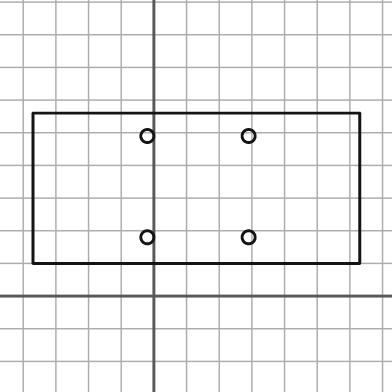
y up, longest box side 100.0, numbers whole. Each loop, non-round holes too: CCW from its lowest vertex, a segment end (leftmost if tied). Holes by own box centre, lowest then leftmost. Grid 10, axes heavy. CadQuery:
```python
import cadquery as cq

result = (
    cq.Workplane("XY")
    .moveTo(-37.0, 10.0)
    .lineTo(63.0, 10.0)
    .lineTo(63.0, 56.0)
    .lineTo(-37.0, 56.0)
    .close()
    .moveTo(-2.0, 18.0)
    .circle(2.0)
    .moveTo(29.0, 18.0)
    .circle(2.0)
    .moveTo(-2.0, 49.0)
    .circle(2.0)
    .moveTo(29.0, 49.0)
    .circle(2.0)
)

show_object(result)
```